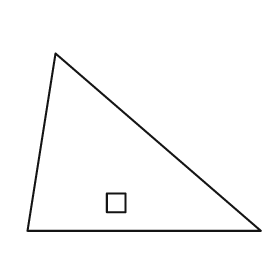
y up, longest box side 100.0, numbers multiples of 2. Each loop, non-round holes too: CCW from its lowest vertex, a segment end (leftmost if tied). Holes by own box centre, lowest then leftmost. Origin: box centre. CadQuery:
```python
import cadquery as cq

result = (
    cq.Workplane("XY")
    .moveTo(-50.0, -38.0)
    .lineTo(50.0, -38.0)
    .lineTo(-38.0, 38.0)
    .close()
    .moveTo(-16.0, -30.0)
    .lineTo(-8.0, -30.0)
    .lineTo(-8.0, -22.0)
    .lineTo(-16.0, -22.0)
    .close()
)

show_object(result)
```